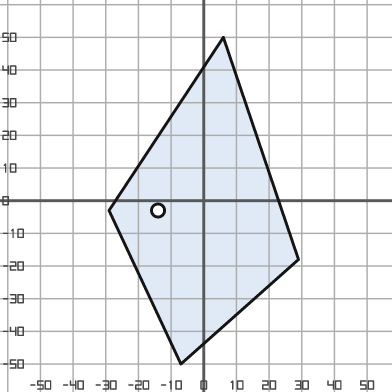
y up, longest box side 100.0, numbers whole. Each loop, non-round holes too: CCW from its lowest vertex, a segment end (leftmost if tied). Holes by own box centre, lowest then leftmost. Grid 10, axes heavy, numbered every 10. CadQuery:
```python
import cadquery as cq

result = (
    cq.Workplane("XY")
    .moveTo(-7.0, -50.0)
    .lineTo(29.0, -18.0)
    .lineTo(6.0, 50.0)
    .lineTo(-29.0, -3.0)
    .close()
    .moveTo(-14.0, -3.0)
    .circle(2.0)
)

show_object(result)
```